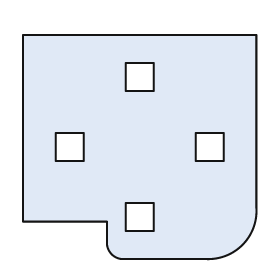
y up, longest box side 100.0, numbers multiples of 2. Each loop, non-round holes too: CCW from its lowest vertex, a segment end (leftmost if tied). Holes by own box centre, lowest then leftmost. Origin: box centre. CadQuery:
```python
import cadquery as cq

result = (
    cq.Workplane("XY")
    .moveTo(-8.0, -48.0)
    .lineTo(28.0, -48.0)
    .threePointArc((44.0, -42.0), (50.0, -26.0))
    .lineTo(50.0, 48.0)
    .lineTo(-50.0, 48.0)
    .lineTo(-50.0, -32.0)
    .lineTo(-14.0, -32.0)
    .lineTo(-14.0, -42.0)
    .threePointArc((-12.0, -46.0), (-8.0, -48.0))
    .close()
    .moveTo(-6.0, -36.0)
    .lineTo(6.0, -36.0)
    .lineTo(6.0, -24.0)
    .lineTo(-6.0, -24.0)
    .close()
    .moveTo(-36.0, -6.0)
    .lineTo(-24.0, -6.0)
    .lineTo(-24.0, 6.0)
    .lineTo(-36.0, 6.0)
    .close()
    .moveTo(24.0, -6.0)
    .lineTo(36.0, -6.0)
    .lineTo(36.0, 6.0)
    .lineTo(24.0, 6.0)
    .close()
    .moveTo(-6.0, 24.0)
    .lineTo(6.0, 24.0)
    .lineTo(6.0, 36.0)
    .lineTo(-6.0, 36.0)
    .close()
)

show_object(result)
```